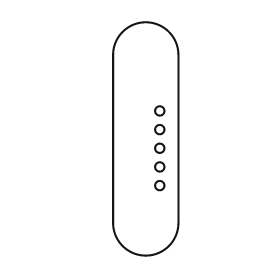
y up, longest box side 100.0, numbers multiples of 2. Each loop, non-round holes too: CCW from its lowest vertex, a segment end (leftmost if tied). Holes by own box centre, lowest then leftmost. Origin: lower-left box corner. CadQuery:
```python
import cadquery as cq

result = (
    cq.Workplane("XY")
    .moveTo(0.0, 14.0)
    .threePointArc((14.0, 0.0), (28.0, 14.0))
    .lineTo(28.0, 86.0)
    .threePointArc((14.0, 100.0), (0.0, 86.0))
    .close()
    .moveTo(20.0, 30.0)
    .circle(2.0)
    .moveTo(20.0, 38.0)
    .circle(2.0)
    .moveTo(20.0, 46.0)
    .circle(2.0)
    .moveTo(20.0, 54.0)
    .circle(2.0)
    .moveTo(20.0, 62.0)
    .circle(2.0)
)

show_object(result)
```